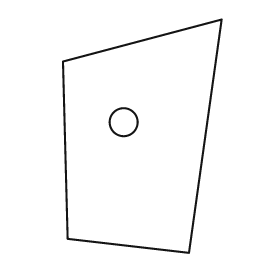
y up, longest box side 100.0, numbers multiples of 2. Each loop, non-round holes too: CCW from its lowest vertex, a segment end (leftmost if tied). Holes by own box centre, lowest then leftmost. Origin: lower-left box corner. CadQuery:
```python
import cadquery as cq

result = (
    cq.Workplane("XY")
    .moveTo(54.0, 0.0)
    .lineTo(68.0, 100.0)
    .lineTo(0.0, 82.0)
    .lineTo(2.0, 6.0)
    .close()
    .moveTo(26.0, 56.0)
    .circle(6.0)
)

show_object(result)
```